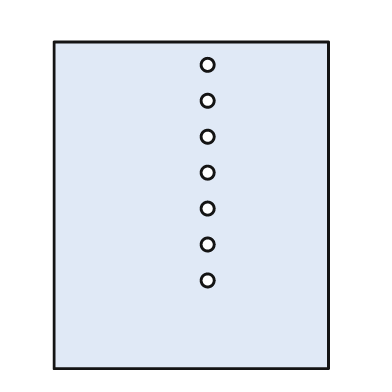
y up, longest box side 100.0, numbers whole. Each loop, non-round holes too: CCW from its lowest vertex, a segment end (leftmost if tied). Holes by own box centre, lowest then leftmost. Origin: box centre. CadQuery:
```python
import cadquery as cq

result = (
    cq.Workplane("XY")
    .moveTo(-42.0, -50.0)
    .lineTo(42.0, -50.0)
    .lineTo(42.0, 50.0)
    .lineTo(-42.0, 50.0)
    .close()
    .moveTo(5.0, -23.0)
    .circle(2.0)
    .moveTo(5.0, -12.0)
    .circle(2.0)
    .moveTo(5.0, -1.0)
    .circle(2.0)
    .moveTo(5.0, 10.0)
    .circle(2.0)
    .moveTo(5.0, 21.0)
    .circle(2.0)
    .moveTo(5.0, 32.0)
    .circle(2.0)
    .moveTo(5.0, 43.0)
    .circle(2.0)
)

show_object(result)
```